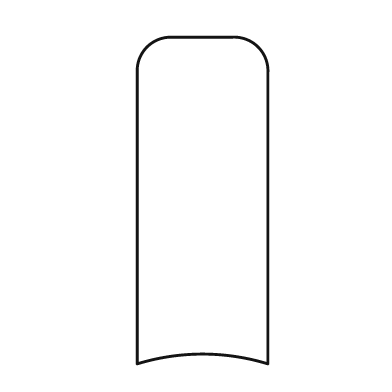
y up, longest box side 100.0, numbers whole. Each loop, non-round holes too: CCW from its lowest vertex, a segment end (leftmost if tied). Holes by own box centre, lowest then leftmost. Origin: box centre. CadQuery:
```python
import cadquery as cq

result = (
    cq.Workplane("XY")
    .moveTo(-20.0, -50.0)
    .threePointArc((0.0, -47.0), (20.0, -50.0))
    .lineTo(20.0, 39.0)
    .threePointArc((17.0, 47.0), (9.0, 50.0))
    .lineTo(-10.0, 50.0)
    .threePointArc((-17.0, 47.0), (-20.0, 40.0))
    .close()
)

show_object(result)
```